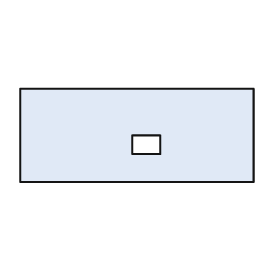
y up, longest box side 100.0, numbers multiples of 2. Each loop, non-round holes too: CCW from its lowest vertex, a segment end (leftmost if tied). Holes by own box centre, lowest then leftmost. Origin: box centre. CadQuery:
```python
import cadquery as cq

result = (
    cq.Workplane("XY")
    .moveTo(-50.0, -20.0)
    .lineTo(50.0, -20.0)
    .lineTo(50.0, 20.0)
    .lineTo(-50.0, 20.0)
    .close()
    .moveTo(-2.0, -8.0)
    .lineTo(10.0, -8.0)
    .lineTo(10.0, 0.0)
    .lineTo(-2.0, 0.0)
    .close()
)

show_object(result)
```